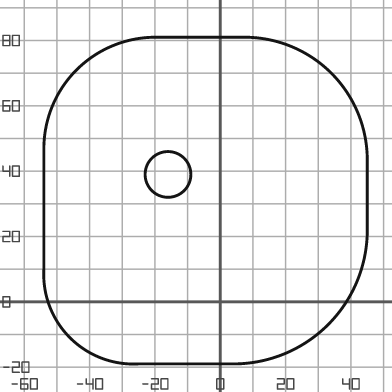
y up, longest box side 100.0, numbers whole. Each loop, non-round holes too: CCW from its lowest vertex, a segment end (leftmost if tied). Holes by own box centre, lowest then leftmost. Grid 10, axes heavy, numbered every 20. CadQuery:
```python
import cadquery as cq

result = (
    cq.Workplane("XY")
    .moveTo(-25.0, -19.0)
    .lineTo(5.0, -19.0)
    .threePointArc((33.0, -7.0), (45.0, 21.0))
    .lineTo(45.0, 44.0)
    .threePointArc((34.0, 70.0), (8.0, 81.0))
    .lineTo(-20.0, 81.0)
    .threePointArc((-44.0, 71.0), (-54.0, 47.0))
    .lineTo(-54.0, 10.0)
    .threePointArc((-46.0, -11.0), (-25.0, -19.0))
    .close()
    .moveTo(-16.0, 39.0)
    .circle(7.0)
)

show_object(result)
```